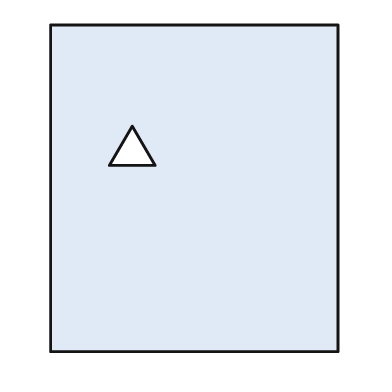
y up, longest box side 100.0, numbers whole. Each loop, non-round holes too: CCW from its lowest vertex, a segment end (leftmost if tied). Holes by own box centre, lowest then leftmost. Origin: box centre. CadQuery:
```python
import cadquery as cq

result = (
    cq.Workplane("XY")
    .moveTo(-44.0, -50.0)
    .lineTo(44.0, -50.0)
    .lineTo(44.0, 50.0)
    .lineTo(-44.0, 50.0)
    .close()
    .moveTo(-26.0, 7.0)
    .lineTo(-12.0, 7.0)
    .lineTo(-19.0, 19.0)
    .close()
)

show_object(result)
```